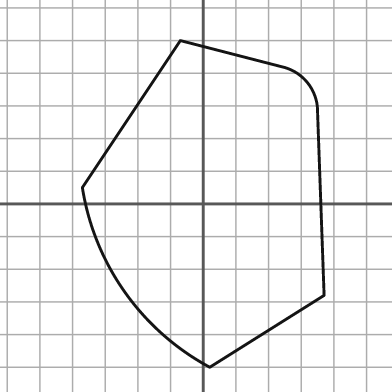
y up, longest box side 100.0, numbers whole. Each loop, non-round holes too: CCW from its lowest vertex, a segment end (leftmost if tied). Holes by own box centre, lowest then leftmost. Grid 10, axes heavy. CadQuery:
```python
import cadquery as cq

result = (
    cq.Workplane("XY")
    .moveTo(2.0, -50.0)
    .lineTo(37.0, -28.0)
    .lineTo(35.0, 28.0)
    .threePointArc((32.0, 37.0), (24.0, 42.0))
    .lineTo(-7.0, 50.0)
    .lineTo(-37.0, 5.0)
    .threePointArc((-24.0, -27.0), (2.0, -50.0))
    .close()
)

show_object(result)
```